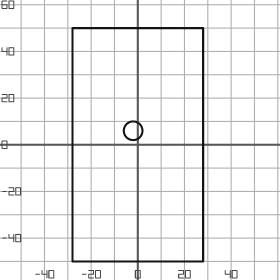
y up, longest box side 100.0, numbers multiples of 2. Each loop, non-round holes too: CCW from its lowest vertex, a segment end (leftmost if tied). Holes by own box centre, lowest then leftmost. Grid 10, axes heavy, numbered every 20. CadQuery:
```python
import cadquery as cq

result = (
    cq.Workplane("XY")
    .moveTo(-28.0, -50.0)
    .lineTo(28.0, -50.0)
    .lineTo(28.0, 50.0)
    .lineTo(-28.0, 50.0)
    .close()
    .moveTo(-2.0, 6.0)
    .circle(4.0)
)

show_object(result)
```